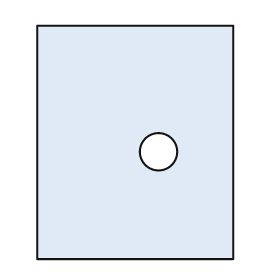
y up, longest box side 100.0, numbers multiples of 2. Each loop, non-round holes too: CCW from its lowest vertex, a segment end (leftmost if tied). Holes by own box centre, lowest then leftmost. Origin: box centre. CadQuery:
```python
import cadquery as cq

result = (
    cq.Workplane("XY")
    .moveTo(-42.0, -50.0)
    .lineTo(42.0, -50.0)
    .lineTo(42.0, 50.0)
    .lineTo(-42.0, 50.0)
    .close()
    .moveTo(10.0, -4.0)
    .circle(8.0)
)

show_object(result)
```